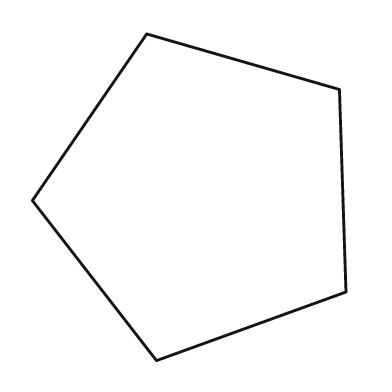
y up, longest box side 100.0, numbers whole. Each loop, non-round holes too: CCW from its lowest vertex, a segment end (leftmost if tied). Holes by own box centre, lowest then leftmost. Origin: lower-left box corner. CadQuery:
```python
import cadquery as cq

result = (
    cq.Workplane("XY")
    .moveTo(38.0, 0.0)
    .lineTo(96.0, 21.0)
    .lineTo(94.0, 83.0)
    .lineTo(35.0, 100.0)
    .lineTo(0.0, 49.0)
    .close()
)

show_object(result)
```